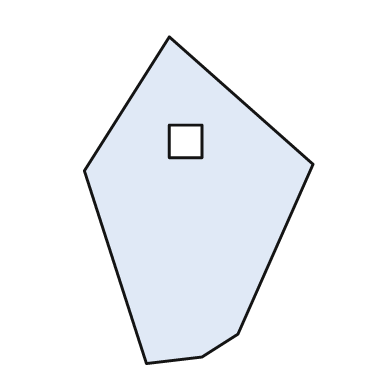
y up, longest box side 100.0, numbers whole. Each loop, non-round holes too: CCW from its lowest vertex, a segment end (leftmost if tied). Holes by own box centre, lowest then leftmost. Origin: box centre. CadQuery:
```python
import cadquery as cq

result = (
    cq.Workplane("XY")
    .moveTo(-16.0, -50.0)
    .lineTo(1.0, -48.0)
    .lineTo(12.0, -41.0)
    .lineTo(35.0, 11.0)
    .lineTo(-9.0, 50.0)
    .lineTo(-35.0, 9.0)
    .close()
    .moveTo(-9.0, 13.0)
    .lineTo(1.0, 13.0)
    .lineTo(1.0, 23.0)
    .lineTo(-9.0, 23.0)
    .close()
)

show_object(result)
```